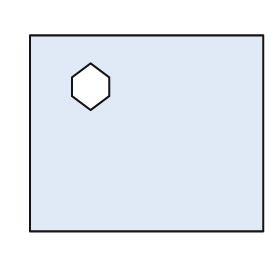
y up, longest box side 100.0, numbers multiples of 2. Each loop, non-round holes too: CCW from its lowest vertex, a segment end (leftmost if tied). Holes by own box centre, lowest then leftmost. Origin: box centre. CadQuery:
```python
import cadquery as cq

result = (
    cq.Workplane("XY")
    .moveTo(-50.0, -42.0)
    .lineTo(50.0, -42.0)
    .lineTo(50.0, 42.0)
    .lineTo(-50.0, 42.0)
    .close()
    .moveTo(-24.0, 10.0)
    .lineTo(-16.0, 16.0)
    .lineTo(-16.0, 24.0)
    .lineTo(-24.0, 30.0)
    .lineTo(-32.0, 24.0)
    .lineTo(-32.0, 16.0)
    .close()
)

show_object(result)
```